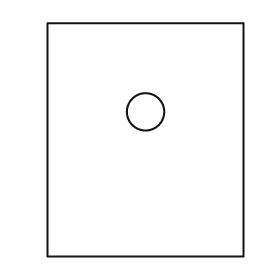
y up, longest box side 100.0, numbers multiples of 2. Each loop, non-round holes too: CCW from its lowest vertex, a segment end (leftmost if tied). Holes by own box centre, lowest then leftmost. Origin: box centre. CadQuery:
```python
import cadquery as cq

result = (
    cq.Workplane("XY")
    .moveTo(-42.0, -50.0)
    .lineTo(42.0, -50.0)
    .lineTo(42.0, 50.0)
    .lineTo(-42.0, 50.0)
    .close()
    .moveTo(0.0, 12.0)
    .circle(8.0)
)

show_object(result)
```